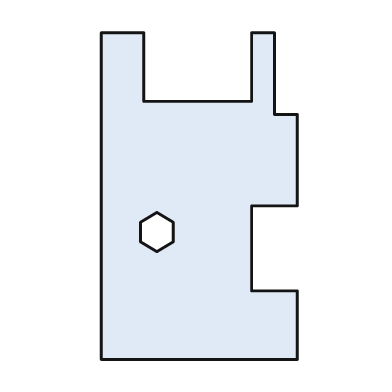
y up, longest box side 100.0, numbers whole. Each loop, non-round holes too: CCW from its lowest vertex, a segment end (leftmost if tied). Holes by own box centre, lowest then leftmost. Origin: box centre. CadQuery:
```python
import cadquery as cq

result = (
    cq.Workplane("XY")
    .moveTo(-30.0, -50.0)
    .lineTo(30.0, -50.0)
    .lineTo(30.0, -29.0)
    .lineTo(16.0, -29.0)
    .lineTo(16.0, -3.0)
    .lineTo(30.0, -3.0)
    .lineTo(30.0, 25.0)
    .lineTo(23.0, 25.0)
    .lineTo(23.0, 50.0)
    .lineTo(16.0, 50.0)
    .lineTo(16.0, 29.0)
    .lineTo(-17.0, 29.0)
    .lineTo(-17.0, 50.0)
    .lineTo(-30.0, 50.0)
    .close()
    .moveTo(-13.0, -17.0)
    .lineTo(-8.0, -14.0)
    .lineTo(-8.0, -8.0)
    .lineTo(-13.0, -5.0)
    .lineTo(-18.0, -8.0)
    .lineTo(-18.0, -14.0)
    .close()
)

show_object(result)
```